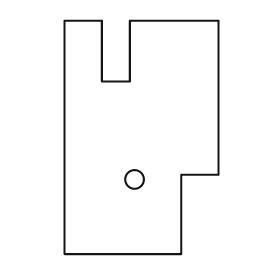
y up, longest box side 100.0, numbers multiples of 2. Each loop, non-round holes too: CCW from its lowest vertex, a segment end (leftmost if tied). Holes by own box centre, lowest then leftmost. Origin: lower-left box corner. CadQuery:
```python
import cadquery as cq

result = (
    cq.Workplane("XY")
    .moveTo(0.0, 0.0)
    .lineTo(50.0, 0.0)
    .lineTo(50.0, 34.0)
    .lineTo(66.0, 34.0)
    .lineTo(66.0, 100.0)
    .lineTo(28.0, 100.0)
    .lineTo(28.0, 74.0)
    .lineTo(16.0, 74.0)
    .lineTo(16.0, 100.0)
    .lineTo(0.0, 100.0)
    .close()
    .moveTo(30.0, 32.0)
    .circle(4.0)
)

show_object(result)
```